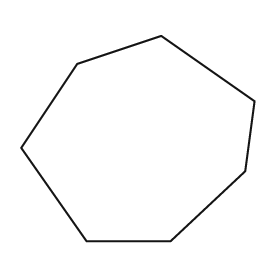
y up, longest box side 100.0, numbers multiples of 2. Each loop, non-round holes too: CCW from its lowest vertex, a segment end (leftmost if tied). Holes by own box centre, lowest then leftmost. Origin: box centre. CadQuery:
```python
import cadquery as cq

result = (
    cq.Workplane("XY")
    .moveTo(-22.0, -44.0)
    .lineTo(14.0, -44.0)
    .lineTo(46.0, -14.0)
    .lineTo(50.0, 16.0)
    .lineTo(10.0, 44.0)
    .lineTo(-26.0, 32.0)
    .lineTo(-50.0, -4.0)
    .close()
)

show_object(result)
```